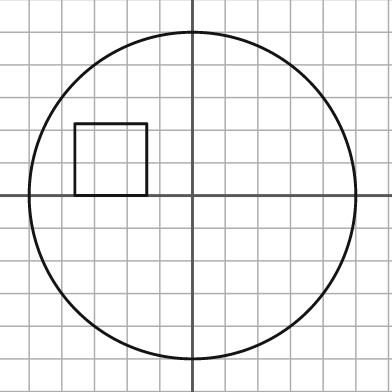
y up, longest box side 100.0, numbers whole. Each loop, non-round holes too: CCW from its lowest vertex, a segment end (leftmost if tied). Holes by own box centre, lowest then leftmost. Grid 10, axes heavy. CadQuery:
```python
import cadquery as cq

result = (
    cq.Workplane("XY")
    .moveTo(0.0, 0.0)
    .circle(50.0)
    .moveTo(-36.0, 0.0)
    .lineTo(-14.0, 0.0)
    .lineTo(-14.0, 22.0)
    .lineTo(-36.0, 22.0)
    .close()
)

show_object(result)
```